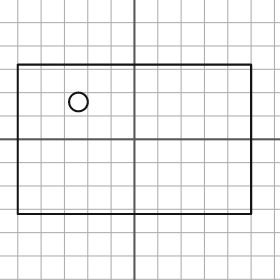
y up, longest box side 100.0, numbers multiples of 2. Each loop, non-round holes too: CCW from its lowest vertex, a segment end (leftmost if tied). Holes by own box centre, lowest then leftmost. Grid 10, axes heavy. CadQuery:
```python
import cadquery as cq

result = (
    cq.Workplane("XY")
    .moveTo(-50.0, -32.0)
    .lineTo(50.0, -32.0)
    .lineTo(50.0, 32.0)
    .lineTo(-50.0, 32.0)
    .close()
    .moveTo(-24.0, 16.0)
    .circle(4.0)
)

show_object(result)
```